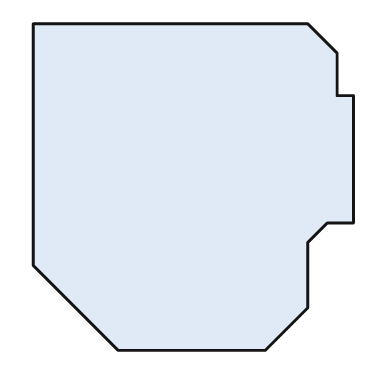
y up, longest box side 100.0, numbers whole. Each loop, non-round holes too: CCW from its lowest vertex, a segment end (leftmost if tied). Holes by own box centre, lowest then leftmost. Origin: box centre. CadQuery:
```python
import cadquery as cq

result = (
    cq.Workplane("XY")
    .moveTo(-23.0, -50.0)
    .lineTo(22.0, -50.0)
    .lineTo(35.0, -37.0)
    .lineTo(35.0, -17.0)
    .lineTo(41.0, -11.0)
    .lineTo(49.0, -11.0)
    .lineTo(49.0, 28.0)
    .lineTo(44.0, 28.0)
    .lineTo(44.0, 41.0)
    .lineTo(35.0, 50.0)
    .lineTo(-49.0, 50.0)
    .lineTo(-49.0, -24.0)
    .close()
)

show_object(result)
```